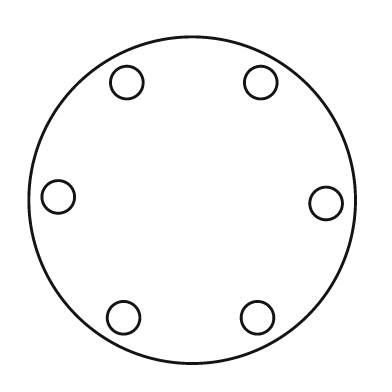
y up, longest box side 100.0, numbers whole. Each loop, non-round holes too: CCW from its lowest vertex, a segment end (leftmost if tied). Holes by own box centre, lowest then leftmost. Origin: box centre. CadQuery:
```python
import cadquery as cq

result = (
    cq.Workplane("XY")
    .moveTo(0.0, 0.0)
    .circle(50.0)
    .moveTo(-21.0, -36.0)
    .circle(5.0)
    .moveTo(20.0, -36.0)
    .circle(5.0)
    .moveTo(41.0, -1.0)
    .circle(5.0)
    .moveTo(-41.0, 1.0)
    .circle(5.0)
    .moveTo(-20.0, 36.0)
    .circle(5.0)
    .moveTo(21.0, 36.0)
    .circle(5.0)
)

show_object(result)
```